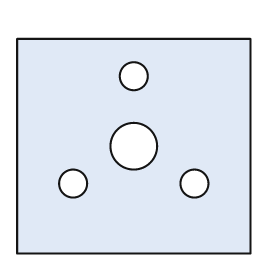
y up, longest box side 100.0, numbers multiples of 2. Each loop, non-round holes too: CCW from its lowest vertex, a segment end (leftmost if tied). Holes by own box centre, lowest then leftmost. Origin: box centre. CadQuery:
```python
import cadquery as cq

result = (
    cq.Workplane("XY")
    .moveTo(-50.0, -46.0)
    .lineTo(50.0, -46.0)
    .lineTo(50.0, 46.0)
    .lineTo(-50.0, 46.0)
    .close()
    .moveTo(-26.0, -16.0)
    .circle(6.0)
    .moveTo(26.0, -16.0)
    .circle(6.0)
    .moveTo(0.0, 0.0)
    .circle(10.0)
    .moveTo(0.0, 30.0)
    .circle(6.0)
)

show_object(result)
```